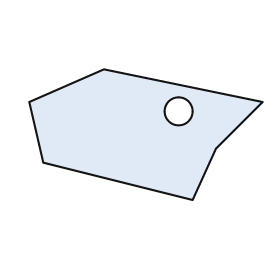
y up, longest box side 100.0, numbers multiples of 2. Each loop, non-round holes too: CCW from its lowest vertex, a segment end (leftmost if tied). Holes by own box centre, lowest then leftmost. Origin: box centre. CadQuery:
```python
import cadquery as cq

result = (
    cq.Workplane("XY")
    .moveTo(20.0, -28.0)
    .lineTo(30.0, -6.0)
    .lineTo(50.0, 14.0)
    .lineTo(-18.0, 28.0)
    .lineTo(-50.0, 14.0)
    .lineTo(-44.0, -12.0)
    .close()
    .moveTo(14.0, 10.0)
    .circle(6.0)
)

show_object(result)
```